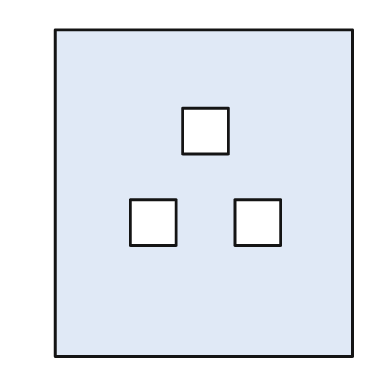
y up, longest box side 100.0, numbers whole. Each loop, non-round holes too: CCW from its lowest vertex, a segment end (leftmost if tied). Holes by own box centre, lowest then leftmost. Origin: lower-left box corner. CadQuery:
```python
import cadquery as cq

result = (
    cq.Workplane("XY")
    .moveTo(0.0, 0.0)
    .lineTo(91.0, 0.0)
    .lineTo(91.0, 100.0)
    .lineTo(0.0, 100.0)
    .close()
    .moveTo(23.0, 34.0)
    .lineTo(37.0, 34.0)
    .lineTo(37.0, 48.0)
    .lineTo(23.0, 48.0)
    .close()
    .moveTo(55.0, 34.0)
    .lineTo(69.0, 34.0)
    .lineTo(69.0, 48.0)
    .lineTo(55.0, 48.0)
    .close()
    .moveTo(39.0, 62.0)
    .lineTo(53.0, 62.0)
    .lineTo(53.0, 76.0)
    .lineTo(39.0, 76.0)
    .close()
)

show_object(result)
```